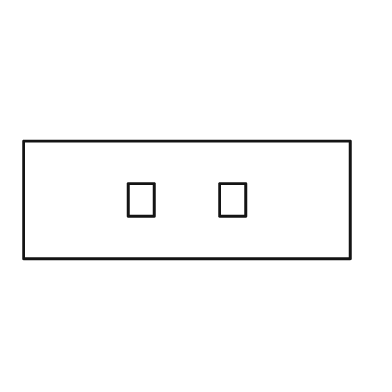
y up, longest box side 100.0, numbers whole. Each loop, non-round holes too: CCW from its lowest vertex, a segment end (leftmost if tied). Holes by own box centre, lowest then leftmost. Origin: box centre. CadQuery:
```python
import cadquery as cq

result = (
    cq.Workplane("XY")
    .moveTo(-50.0, -18.0)
    .lineTo(50.0, -18.0)
    .lineTo(50.0, 18.0)
    .lineTo(-50.0, 18.0)
    .close()
    .moveTo(-18.0, -5.0)
    .lineTo(-10.0, -5.0)
    .lineTo(-10.0, 5.0)
    .lineTo(-18.0, 5.0)
    .close()
    .moveTo(10.0, -5.0)
    .lineTo(18.0, -5.0)
    .lineTo(18.0, 5.0)
    .lineTo(10.0, 5.0)
    .close()
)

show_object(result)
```